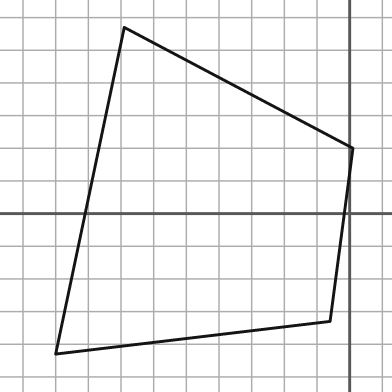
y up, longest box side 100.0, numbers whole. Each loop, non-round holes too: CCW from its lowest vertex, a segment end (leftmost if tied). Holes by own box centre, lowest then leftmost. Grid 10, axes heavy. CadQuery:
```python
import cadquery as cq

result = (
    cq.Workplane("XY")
    .moveTo(-90.0, -43.0)
    .lineTo(-6.0, -33.0)
    .lineTo(1.0, 20.0)
    .lineTo(-69.0, 57.0)
    .close()
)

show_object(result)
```